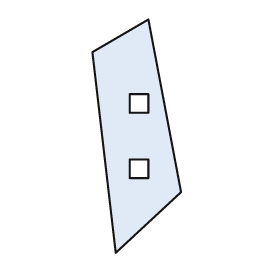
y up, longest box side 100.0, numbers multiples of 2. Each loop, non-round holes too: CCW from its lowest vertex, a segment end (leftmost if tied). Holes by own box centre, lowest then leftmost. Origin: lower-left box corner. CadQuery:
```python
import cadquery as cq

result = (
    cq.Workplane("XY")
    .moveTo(10.0, 0.0)
    .lineTo(38.0, 26.0)
    .lineTo(24.0, 100.0)
    .lineTo(0.0, 86.0)
    .close()
    .moveTo(16.0, 32.0)
    .lineTo(24.0, 32.0)
    .lineTo(24.0, 40.0)
    .lineTo(16.0, 40.0)
    .close()
    .moveTo(16.0, 60.0)
    .lineTo(24.0, 60.0)
    .lineTo(24.0, 68.0)
    .lineTo(16.0, 68.0)
    .close()
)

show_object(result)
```